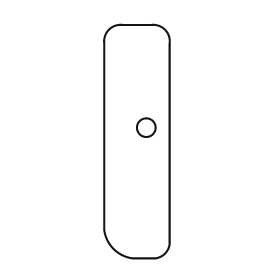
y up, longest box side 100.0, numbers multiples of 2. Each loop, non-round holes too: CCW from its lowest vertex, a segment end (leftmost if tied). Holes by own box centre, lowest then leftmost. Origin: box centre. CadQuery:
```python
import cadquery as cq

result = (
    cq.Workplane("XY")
    .moveTo(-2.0, -50.0)
    .lineTo(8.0, -50.0)
    .threePointArc((12.0, -48.0), (14.0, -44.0))
    .lineTo(14.0, 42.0)
    .threePointArc((12.0, 48.0), (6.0, 50.0))
    .lineTo(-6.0, 50.0)
    .threePointArc((-12.0, 48.0), (-14.0, 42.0))
    .lineTo(-14.0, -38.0)
    .threePointArc((-10.0, -46.0), (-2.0, -50.0))
    .close()
    .moveTo(4.0, 6.0)
    .circle(4.0)
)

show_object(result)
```